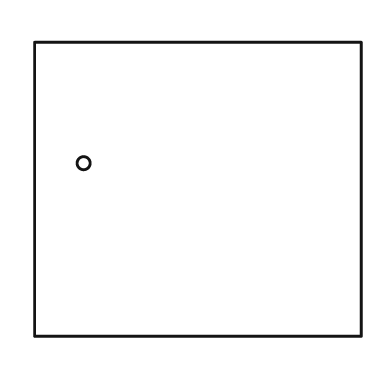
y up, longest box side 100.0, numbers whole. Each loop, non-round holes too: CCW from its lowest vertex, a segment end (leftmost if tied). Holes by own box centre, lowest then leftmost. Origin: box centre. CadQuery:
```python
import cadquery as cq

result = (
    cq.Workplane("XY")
    .moveTo(-50.0, -45.0)
    .lineTo(50.0, -45.0)
    .lineTo(50.0, 45.0)
    .lineTo(-50.0, 45.0)
    .close()
    .moveTo(-35.0, 8.0)
    .circle(2.0)
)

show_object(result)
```